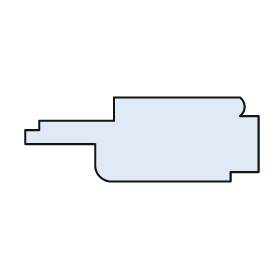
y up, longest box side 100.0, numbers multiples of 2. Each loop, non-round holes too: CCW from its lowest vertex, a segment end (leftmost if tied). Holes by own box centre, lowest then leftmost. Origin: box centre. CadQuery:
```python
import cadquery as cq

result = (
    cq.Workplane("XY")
    .moveTo(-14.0, -18.0)
    .lineTo(38.0, -18.0)
    .lineTo(38.0, -14.0)
    .lineTo(50.0, -14.0)
    .lineTo(50.0, 10.0)
    .lineTo(42.0, 10.0)
    .threePointArc((44.0, 14.0), (42.0, 18.0))
    .lineTo(-12.0, 18.0)
    .lineTo(-12.0, 8.0)
    .lineTo(-44.0, 8.0)
    .lineTo(-44.0, 4.0)
    .lineTo(-50.0, 4.0)
    .lineTo(-50.0, -2.0)
    .lineTo(-20.0, -2.0)
    .lineTo(-20.0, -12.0)
    .threePointArc((-18.0, -16.0), (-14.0, -18.0))
    .close()
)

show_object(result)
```